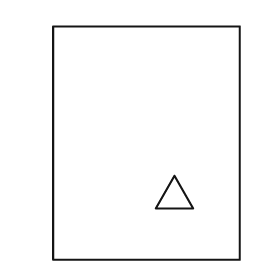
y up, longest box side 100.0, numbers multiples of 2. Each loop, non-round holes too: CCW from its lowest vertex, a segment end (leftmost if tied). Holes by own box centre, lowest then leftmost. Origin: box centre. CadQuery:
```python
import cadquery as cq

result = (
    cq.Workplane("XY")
    .moveTo(-40.0, -50.0)
    .lineTo(40.0, -50.0)
    .lineTo(40.0, 50.0)
    .lineTo(-40.0, 50.0)
    .close()
    .moveTo(4.0, -28.0)
    .lineTo(20.0, -28.0)
    .lineTo(12.0, -14.0)
    .close()
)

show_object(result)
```